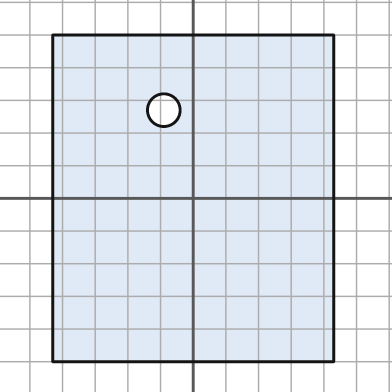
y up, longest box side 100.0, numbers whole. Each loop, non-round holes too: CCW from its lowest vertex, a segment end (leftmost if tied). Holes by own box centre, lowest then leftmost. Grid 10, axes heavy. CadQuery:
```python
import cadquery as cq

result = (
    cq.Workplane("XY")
    .moveTo(-43.0, -50.0)
    .lineTo(43.0, -50.0)
    .lineTo(43.0, 50.0)
    .lineTo(-43.0, 50.0)
    .close()
    .moveTo(-9.0, 27.0)
    .circle(5.0)
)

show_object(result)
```